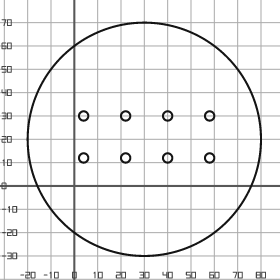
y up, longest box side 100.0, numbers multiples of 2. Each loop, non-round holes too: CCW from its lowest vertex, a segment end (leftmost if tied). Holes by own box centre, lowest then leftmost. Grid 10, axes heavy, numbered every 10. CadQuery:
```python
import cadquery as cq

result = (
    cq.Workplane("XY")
    .moveTo(30.0, 20.0)
    .circle(50.0)
    .moveTo(4.0, 12.0)
    .circle(2.0)
    .moveTo(22.0, 12.0)
    .circle(2.0)
    .moveTo(40.0, 12.0)
    .circle(2.0)
    .moveTo(58.0, 12.0)
    .circle(2.0)
    .moveTo(4.0, 30.0)
    .circle(2.0)
    .moveTo(22.0, 30.0)
    .circle(2.0)
    .moveTo(40.0, 30.0)
    .circle(2.0)
    .moveTo(58.0, 30.0)
    .circle(2.0)
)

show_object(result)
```